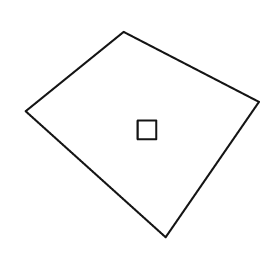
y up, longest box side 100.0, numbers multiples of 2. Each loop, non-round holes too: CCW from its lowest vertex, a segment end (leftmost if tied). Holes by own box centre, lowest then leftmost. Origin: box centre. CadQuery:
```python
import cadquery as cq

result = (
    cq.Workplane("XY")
    .moveTo(10.0, -44.0)
    .lineTo(50.0, 14.0)
    .lineTo(-8.0, 44.0)
    .lineTo(-50.0, 10.0)
    .close()
    .moveTo(-2.0, -2.0)
    .lineTo(6.0, -2.0)
    .lineTo(6.0, 6.0)
    .lineTo(-2.0, 6.0)
    .close()
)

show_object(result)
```